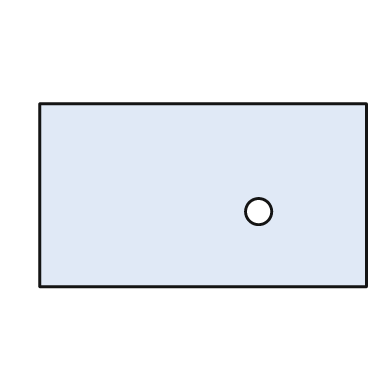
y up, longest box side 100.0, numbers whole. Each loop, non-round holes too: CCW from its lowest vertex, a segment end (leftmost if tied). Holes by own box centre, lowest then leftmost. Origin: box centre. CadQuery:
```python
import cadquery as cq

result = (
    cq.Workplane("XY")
    .moveTo(-50.0, -28.0)
    .lineTo(50.0, -28.0)
    .lineTo(50.0, 28.0)
    .lineTo(-50.0, 28.0)
    .close()
    .moveTo(17.0, -5.0)
    .circle(4.0)
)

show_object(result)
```